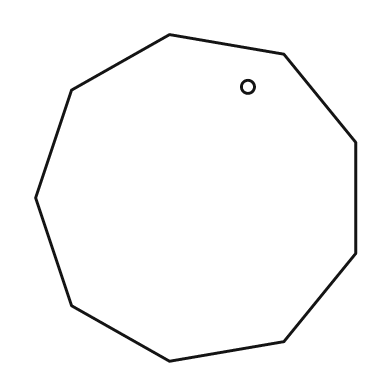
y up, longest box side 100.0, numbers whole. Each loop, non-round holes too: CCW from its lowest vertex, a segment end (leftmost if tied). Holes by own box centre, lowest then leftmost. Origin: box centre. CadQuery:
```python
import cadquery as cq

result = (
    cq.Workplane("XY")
    .moveTo(-8.0, -50.0)
    .lineTo(27.0, -44.0)
    .lineTo(49.0, -17.0)
    .lineTo(49.0, 17.0)
    .lineTo(27.0, 44.0)
    .lineTo(-8.0, 50.0)
    .lineTo(-38.0, 33.0)
    .lineTo(-49.0, 0.0)
    .lineTo(-38.0, -33.0)
    .close()
    .moveTo(16.0, 34.0)
    .circle(2.0)
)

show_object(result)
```